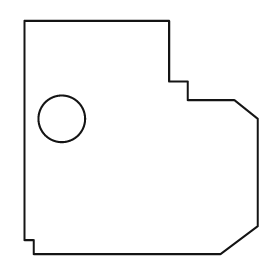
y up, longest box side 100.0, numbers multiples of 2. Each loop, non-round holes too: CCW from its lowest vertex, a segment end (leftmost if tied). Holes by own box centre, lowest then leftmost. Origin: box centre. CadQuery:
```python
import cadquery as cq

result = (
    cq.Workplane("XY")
    .moveTo(-46.0, -50.0)
    .lineTo(34.0, -50.0)
    .lineTo(50.0, -38.0)
    .lineTo(50.0, 8.0)
    .lineTo(40.0, 16.0)
    .lineTo(20.0, 16.0)
    .lineTo(20.0, 24.0)
    .lineTo(12.0, 24.0)
    .lineTo(12.0, 50.0)
    .lineTo(-50.0, 50.0)
    .lineTo(-50.0, -44.0)
    .lineTo(-46.0, -44.0)
    .close()
    .moveTo(-34.0, 8.0)
    .circle(10.0)
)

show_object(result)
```